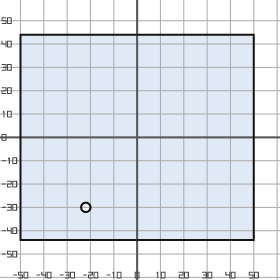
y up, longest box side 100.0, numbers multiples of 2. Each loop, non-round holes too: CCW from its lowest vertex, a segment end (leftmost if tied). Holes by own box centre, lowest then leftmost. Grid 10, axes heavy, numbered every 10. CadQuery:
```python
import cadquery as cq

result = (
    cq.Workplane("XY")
    .moveTo(-50.0, -44.0)
    .lineTo(50.0, -44.0)
    .lineTo(50.0, 44.0)
    .lineTo(-50.0, 44.0)
    .close()
    .moveTo(-22.0, -30.0)
    .circle(2.0)
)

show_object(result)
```